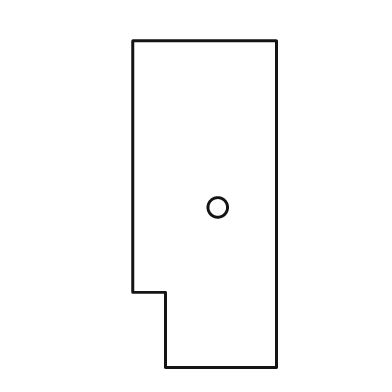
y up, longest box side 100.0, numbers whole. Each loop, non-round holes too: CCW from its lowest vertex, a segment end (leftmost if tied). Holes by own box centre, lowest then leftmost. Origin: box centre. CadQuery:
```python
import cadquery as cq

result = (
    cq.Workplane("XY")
    .moveTo(-12.0, -50.0)
    .lineTo(22.0, -50.0)
    .lineTo(22.0, 50.0)
    .lineTo(-22.0, 50.0)
    .lineTo(-22.0, -27.0)
    .lineTo(-12.0, -27.0)
    .close()
    .moveTo(4.0, -1.0)
    .circle(3.0)
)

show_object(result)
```